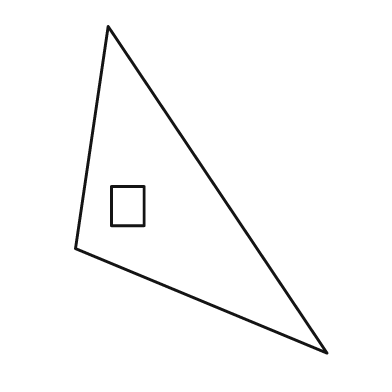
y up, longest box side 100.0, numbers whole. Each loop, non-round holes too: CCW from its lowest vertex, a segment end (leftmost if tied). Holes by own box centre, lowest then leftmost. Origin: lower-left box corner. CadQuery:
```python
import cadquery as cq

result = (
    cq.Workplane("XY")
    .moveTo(77.0, 0.0)
    .lineTo(10.0, 100.0)
    .lineTo(0.0, 32.0)
    .close()
    .moveTo(11.0, 39.0)
    .lineTo(21.0, 39.0)
    .lineTo(21.0, 51.0)
    .lineTo(11.0, 51.0)
    .close()
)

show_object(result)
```